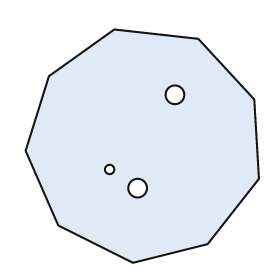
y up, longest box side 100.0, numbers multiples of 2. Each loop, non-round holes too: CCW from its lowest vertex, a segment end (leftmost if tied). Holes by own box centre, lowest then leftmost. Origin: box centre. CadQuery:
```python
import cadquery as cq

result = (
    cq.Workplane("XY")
    .moveTo(-4.0, -50.0)
    .lineTo(28.0, -42.0)
    .lineTo(50.0, -14.0)
    .lineTo(48.0, 20.0)
    .lineTo(24.0, 46.0)
    .lineTo(-12.0, 50.0)
    .lineTo(-40.0, 30.0)
    .lineTo(-50.0, -2.0)
    .lineTo(-36.0, -34.0)
    .close()
    .moveTo(-2.0, -18.0)
    .circle(4.0)
    .moveTo(-14.0, -10.0)
    .circle(2.0)
    .moveTo(14.0, 22.0)
    .circle(4.0)
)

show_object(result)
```